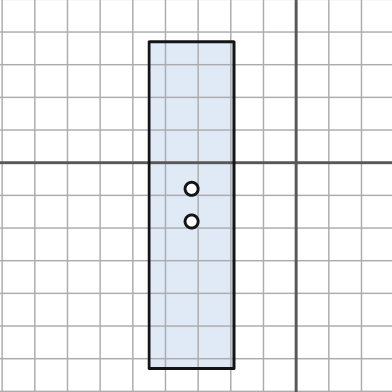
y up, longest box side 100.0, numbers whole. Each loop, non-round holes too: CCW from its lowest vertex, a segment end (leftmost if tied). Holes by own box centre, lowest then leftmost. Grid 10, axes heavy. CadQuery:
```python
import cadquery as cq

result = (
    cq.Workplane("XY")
    .moveTo(-45.0, -63.0)
    .lineTo(-19.0, -63.0)
    .lineTo(-19.0, 37.0)
    .lineTo(-45.0, 37.0)
    .close()
    .moveTo(-32.0, -18.0)
    .circle(2.0)
    .moveTo(-32.0, -8.0)
    .circle(2.0)
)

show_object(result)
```